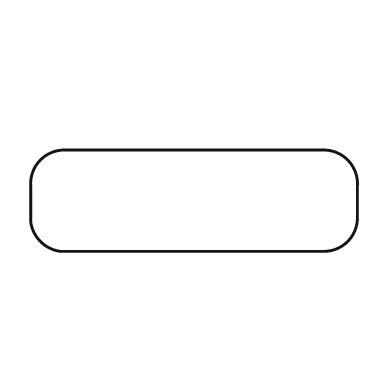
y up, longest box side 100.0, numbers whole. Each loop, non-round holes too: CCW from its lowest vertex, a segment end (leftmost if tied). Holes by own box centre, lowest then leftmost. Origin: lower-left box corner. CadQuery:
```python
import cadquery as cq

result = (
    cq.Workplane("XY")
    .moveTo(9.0, 0.0)
    .lineTo(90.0, 0.0)
    .threePointArc((97.0, 3.0), (100.0, 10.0))
    .lineTo(100.0, 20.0)
    .threePointArc((97.0, 28.0), (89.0, 31.0))
    .lineTo(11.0, 31.0)
    .threePointArc((3.0, 28.0), (0.0, 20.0))
    .lineTo(0.0, 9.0)
    .threePointArc((3.0, 3.0), (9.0, 0.0))
    .close()
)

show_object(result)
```